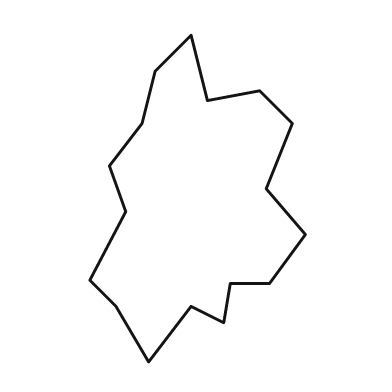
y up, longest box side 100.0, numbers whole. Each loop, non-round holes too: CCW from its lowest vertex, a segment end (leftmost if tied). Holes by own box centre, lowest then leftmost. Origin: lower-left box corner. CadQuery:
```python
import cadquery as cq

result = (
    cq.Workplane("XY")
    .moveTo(18.0, 0.0)
    .lineTo(31.0, 17.0)
    .lineTo(41.0, 12.0)
    .lineTo(43.0, 24.0)
    .lineTo(55.0, 24.0)
    .lineTo(66.0, 39.0)
    .lineTo(54.0, 53.0)
    .lineTo(62.0, 73.0)
    .lineTo(52.0, 83.0)
    .lineTo(36.0, 80.0)
    .lineTo(31.0, 100.0)
    .lineTo(20.0, 89.0)
    .lineTo(16.0, 73.0)
    .lineTo(6.0, 60.0)
    .lineTo(11.0, 46.0)
    .lineTo(0.0, 25.0)
    .lineTo(8.0, 17.0)
    .close()
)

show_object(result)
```